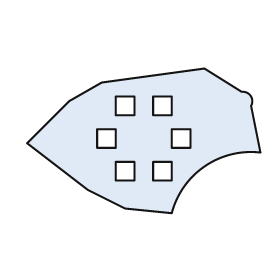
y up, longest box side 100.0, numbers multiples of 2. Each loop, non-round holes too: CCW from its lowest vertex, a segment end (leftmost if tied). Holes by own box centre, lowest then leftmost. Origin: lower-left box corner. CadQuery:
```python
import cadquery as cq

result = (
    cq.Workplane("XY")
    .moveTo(62.0, 0.0)
    .threePointArc((76.0, 20.0), (100.0, 26.0))
    .lineTo(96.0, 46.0)
    .threePointArc((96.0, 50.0), (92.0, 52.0))
    .lineTo(76.0, 62.0)
    .lineTo(32.0, 56.0)
    .lineTo(18.0, 48.0)
    .lineTo(0.0, 30.0)
    .lineTo(26.0, 10.0)
    .lineTo(42.0, 2.0)
    .close()
    .moveTo(38.0, 14.0)
    .lineTo(46.0, 14.0)
    .lineTo(46.0, 22.0)
    .lineTo(38.0, 22.0)
    .close()
    .moveTo(54.0, 14.0)
    .lineTo(62.0, 14.0)
    .lineTo(62.0, 22.0)
    .lineTo(54.0, 22.0)
    .close()
    .moveTo(30.0, 28.0)
    .lineTo(38.0, 28.0)
    .lineTo(38.0, 36.0)
    .lineTo(30.0, 36.0)
    .close()
    .moveTo(62.0, 28.0)
    .lineTo(70.0, 28.0)
    .lineTo(70.0, 36.0)
    .lineTo(62.0, 36.0)
    .close()
    .moveTo(38.0, 42.0)
    .lineTo(46.0, 42.0)
    .lineTo(46.0, 50.0)
    .lineTo(38.0, 50.0)
    .close()
    .moveTo(54.0, 42.0)
    .lineTo(62.0, 42.0)
    .lineTo(62.0, 50.0)
    .lineTo(54.0, 50.0)
    .close()
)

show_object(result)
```